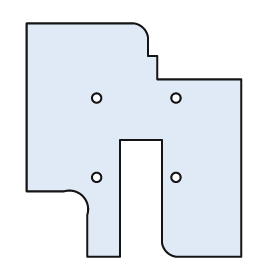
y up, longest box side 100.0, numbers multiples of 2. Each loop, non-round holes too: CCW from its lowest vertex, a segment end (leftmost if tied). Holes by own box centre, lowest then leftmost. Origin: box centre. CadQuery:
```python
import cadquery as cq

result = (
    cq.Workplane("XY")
    .moveTo(-20.0, -50.0)
    .lineTo(-6.0, -50.0)
    .lineTo(-6.0, 0.0)
    .lineTo(12.0, 0.0)
    .lineTo(12.0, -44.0)
    .threePointArc((14.0, -48.0), (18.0, -50.0))
    .lineTo(46.0, -50.0)
    .lineTo(46.0, 26.0)
    .lineTo(10.0, 26.0)
    .lineTo(10.0, 36.0)
    .lineTo(6.0, 36.0)
    .lineTo(6.0, 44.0)
    .threePointArc((4.0, 48.0), (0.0, 50.0))
    .lineTo(-46.0, 50.0)
    .lineTo(-46.0, -22.0)
    .lineTo(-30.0, -22.0)
    .threePointArc((-22.0, -24.0), (-20.0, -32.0))
    .close()
    .moveTo(-16.0, -16.0)
    .circle(2.0)
    .moveTo(18.0, -16.0)
    .circle(2.0)
    .moveTo(-16.0, 18.0)
    .circle(2.0)
    .moveTo(18.0, 18.0)
    .circle(2.0)
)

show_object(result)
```